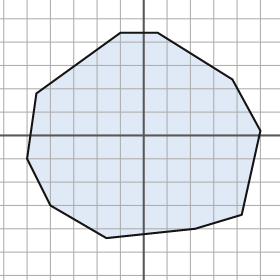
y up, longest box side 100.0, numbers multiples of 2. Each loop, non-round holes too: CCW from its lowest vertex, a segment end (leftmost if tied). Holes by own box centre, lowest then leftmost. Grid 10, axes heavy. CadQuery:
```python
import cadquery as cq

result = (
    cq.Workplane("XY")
    .moveTo(-16.0, -44.0)
    .lineTo(22.0, -40.0)
    .lineTo(42.0, -34.0)
    .lineTo(50.0, 2.0)
    .lineTo(38.0, 24.0)
    .lineTo(6.0, 44.0)
    .lineTo(-10.0, 44.0)
    .lineTo(-46.0, 18.0)
    .lineTo(-50.0, -10.0)
    .lineTo(-40.0, -30.0)
    .close()
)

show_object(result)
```